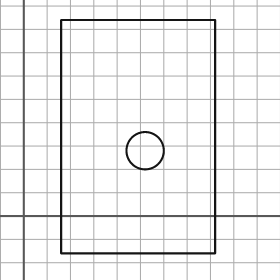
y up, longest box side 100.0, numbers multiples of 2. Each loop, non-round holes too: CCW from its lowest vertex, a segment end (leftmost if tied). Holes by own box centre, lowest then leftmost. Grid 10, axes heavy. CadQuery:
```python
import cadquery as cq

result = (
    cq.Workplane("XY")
    .moveTo(16.0, -16.0)
    .lineTo(82.0, -16.0)
    .lineTo(82.0, 84.0)
    .lineTo(16.0, 84.0)
    .close()
    .moveTo(52.0, 28.0)
    .circle(8.0)
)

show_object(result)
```